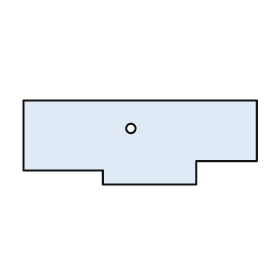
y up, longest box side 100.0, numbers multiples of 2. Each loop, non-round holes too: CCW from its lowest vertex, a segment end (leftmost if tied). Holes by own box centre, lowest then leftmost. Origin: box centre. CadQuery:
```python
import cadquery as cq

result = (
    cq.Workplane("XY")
    .moveTo(-16.0, -18.0)
    .lineTo(24.0, -18.0)
    .lineTo(24.0, -8.0)
    .lineTo(50.0, -8.0)
    .lineTo(50.0, 18.0)
    .lineTo(-50.0, 18.0)
    .lineTo(-50.0, -12.0)
    .lineTo(-16.0, -12.0)
    .close()
    .moveTo(-4.0, 6.0)
    .circle(2.0)
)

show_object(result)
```